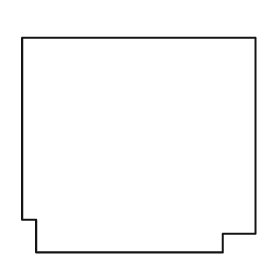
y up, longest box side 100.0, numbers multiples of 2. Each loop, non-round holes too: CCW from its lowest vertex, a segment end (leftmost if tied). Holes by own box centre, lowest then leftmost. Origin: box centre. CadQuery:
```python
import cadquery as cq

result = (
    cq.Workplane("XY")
    .moveTo(-44.0, -46.0)
    .lineTo(36.0, -46.0)
    .lineTo(36.0, -38.0)
    .lineTo(50.0, -38.0)
    .lineTo(50.0, 46.0)
    .lineTo(-50.0, 46.0)
    .lineTo(-50.0, -32.0)
    .lineTo(-44.0, -32.0)
    .close()
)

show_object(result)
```